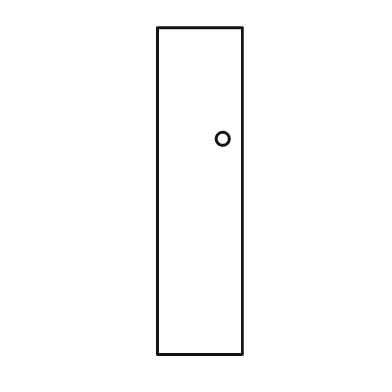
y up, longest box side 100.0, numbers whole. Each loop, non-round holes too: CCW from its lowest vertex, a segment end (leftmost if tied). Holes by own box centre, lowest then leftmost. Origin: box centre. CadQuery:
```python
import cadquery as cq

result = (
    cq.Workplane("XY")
    .moveTo(-13.0, -50.0)
    .lineTo(13.0, -50.0)
    .lineTo(13.0, 50.0)
    .lineTo(-13.0, 50.0)
    .close()
    .moveTo(7.0, 16.0)
    .circle(2.0)
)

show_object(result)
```